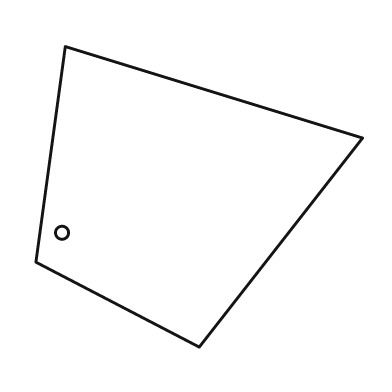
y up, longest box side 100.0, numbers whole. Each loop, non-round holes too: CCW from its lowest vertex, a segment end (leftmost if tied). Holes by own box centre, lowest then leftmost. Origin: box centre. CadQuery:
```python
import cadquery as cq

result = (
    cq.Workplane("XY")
    .moveTo(0.0, -46.0)
    .lineTo(50.0, 18.0)
    .lineTo(-41.0, 46.0)
    .lineTo(-50.0, -20.0)
    .close()
    .moveTo(-42.0, -11.0)
    .circle(2.0)
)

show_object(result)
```